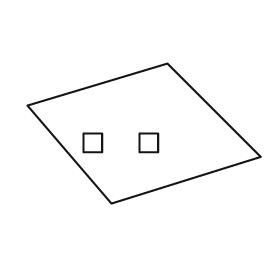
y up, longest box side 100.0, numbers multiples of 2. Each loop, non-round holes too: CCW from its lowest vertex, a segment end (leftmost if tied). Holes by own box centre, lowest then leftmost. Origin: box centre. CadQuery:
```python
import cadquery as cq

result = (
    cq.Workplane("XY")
    .moveTo(-14.0, -30.0)
    .lineTo(50.0, -10.0)
    .lineTo(10.0, 30.0)
    .lineTo(-50.0, 12.0)
    .close()
    .moveTo(-26.0, -8.0)
    .lineTo(-18.0, -8.0)
    .lineTo(-18.0, 0.0)
    .lineTo(-26.0, 0.0)
    .close()
    .moveTo(-2.0, -8.0)
    .lineTo(6.0, -8.0)
    .lineTo(6.0, 0.0)
    .lineTo(-2.0, 0.0)
    .close()
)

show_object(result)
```